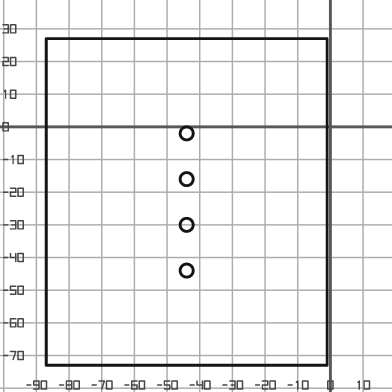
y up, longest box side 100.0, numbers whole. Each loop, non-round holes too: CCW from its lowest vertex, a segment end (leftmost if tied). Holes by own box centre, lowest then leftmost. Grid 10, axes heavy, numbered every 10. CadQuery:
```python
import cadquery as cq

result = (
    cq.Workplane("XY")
    .moveTo(-87.0, -73.0)
    .lineTo(-1.0, -73.0)
    .lineTo(-1.0, 27.0)
    .lineTo(-87.0, 27.0)
    .close()
    .moveTo(-44.0, -44.0)
    .circle(2.0)
    .moveTo(-44.0, -30.0)
    .circle(2.0)
    .moveTo(-44.0, -16.0)
    .circle(2.0)
    .moveTo(-44.0, -2.0)
    .circle(2.0)
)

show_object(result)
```